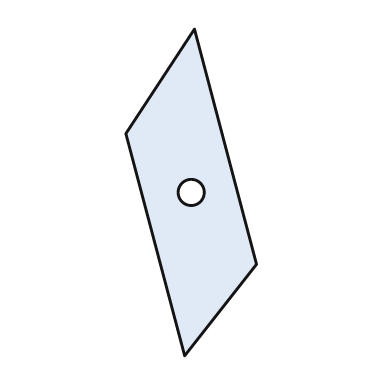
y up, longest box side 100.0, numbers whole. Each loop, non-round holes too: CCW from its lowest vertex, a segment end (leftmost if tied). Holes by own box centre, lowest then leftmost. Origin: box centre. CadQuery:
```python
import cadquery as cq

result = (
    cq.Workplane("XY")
    .moveTo(-2.0, -50.0)
    .lineTo(20.0, -22.0)
    .lineTo(1.0, 50.0)
    .lineTo(-20.0, 18.0)
    .close()
    .moveTo(0.0, 0.0)
    .circle(4.0)
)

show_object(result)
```